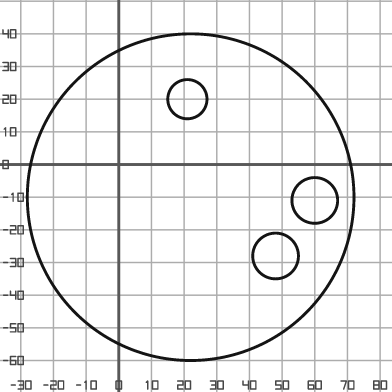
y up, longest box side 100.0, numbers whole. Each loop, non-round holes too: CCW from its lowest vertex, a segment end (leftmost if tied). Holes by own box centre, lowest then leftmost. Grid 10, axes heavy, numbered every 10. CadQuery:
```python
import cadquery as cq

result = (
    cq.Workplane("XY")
    .moveTo(22.0, -10.0)
    .circle(50.0)
    .moveTo(48.0, -28.0)
    .circle(7.0)
    .moveTo(60.0, -11.0)
    .circle(7.0)
    .moveTo(21.0, 20.0)
    .circle(6.0)
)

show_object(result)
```